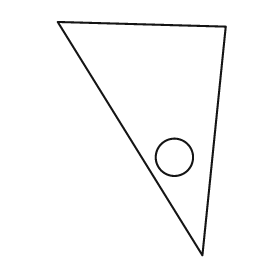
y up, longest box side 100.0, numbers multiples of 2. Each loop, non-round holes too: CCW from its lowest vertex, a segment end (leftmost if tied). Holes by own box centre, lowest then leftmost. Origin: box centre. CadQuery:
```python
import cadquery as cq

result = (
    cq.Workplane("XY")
    .moveTo(26.0, -50.0)
    .lineTo(36.0, 48.0)
    .lineTo(-36.0, 50.0)
    .close()
    .moveTo(14.0, -8.0)
    .circle(8.0)
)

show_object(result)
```